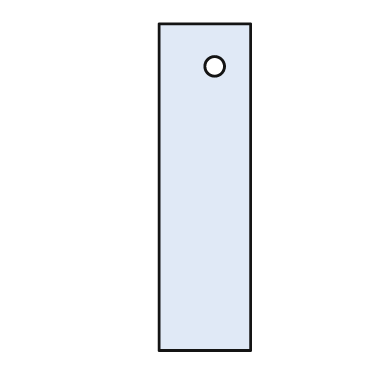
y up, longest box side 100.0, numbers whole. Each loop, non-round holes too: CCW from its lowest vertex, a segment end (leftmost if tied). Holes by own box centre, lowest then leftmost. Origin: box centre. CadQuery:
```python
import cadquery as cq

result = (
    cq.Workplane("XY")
    .moveTo(-14.0, -50.0)
    .lineTo(14.0, -50.0)
    .lineTo(14.0, 50.0)
    .lineTo(-14.0, 50.0)
    .close()
    .moveTo(3.0, 37.0)
    .circle(3.0)
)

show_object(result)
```